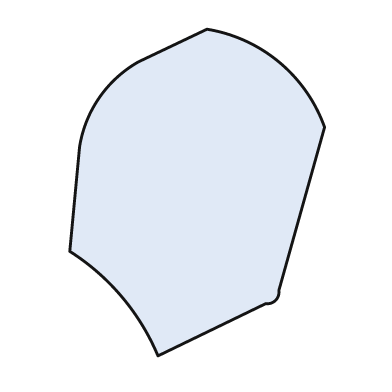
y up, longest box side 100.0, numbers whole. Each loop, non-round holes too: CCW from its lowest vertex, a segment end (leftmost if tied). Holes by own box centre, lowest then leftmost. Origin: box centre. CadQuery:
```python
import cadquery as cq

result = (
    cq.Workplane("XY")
    .moveTo(-12.0, -50.0)
    .lineTo(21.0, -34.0)
    .threePointArc((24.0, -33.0), (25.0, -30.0))
    .lineTo(39.0, 20.0)
    .threePointArc((25.0, 40.0), (3.0, 50.0))
    .lineTo(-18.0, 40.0)
    .threePointArc((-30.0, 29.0), (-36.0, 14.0))
    .lineTo(-39.0, -18.0)
    .threePointArc((-23.0, -32.0), (-12.0, -50.0))
    .close()
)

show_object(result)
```